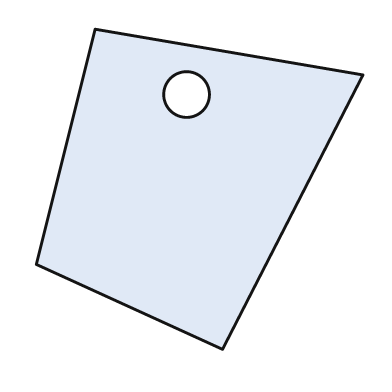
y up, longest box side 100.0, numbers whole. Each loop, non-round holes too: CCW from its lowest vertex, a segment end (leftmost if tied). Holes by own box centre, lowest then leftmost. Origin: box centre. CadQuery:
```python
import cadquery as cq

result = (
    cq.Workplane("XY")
    .moveTo(7.0, -49.0)
    .lineTo(50.0, 35.0)
    .lineTo(-32.0, 49.0)
    .lineTo(-50.0, -23.0)
    .close()
    .moveTo(-4.0, 29.0)
    .circle(7.0)
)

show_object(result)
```